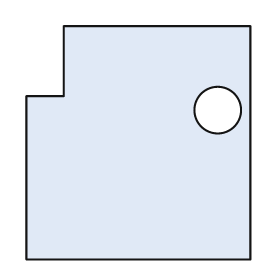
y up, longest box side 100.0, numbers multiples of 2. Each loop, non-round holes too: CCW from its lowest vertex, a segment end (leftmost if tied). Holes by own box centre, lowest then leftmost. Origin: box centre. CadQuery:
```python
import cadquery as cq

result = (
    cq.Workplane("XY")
    .moveTo(-48.0, -50.0)
    .lineTo(48.0, -50.0)
    .lineTo(48.0, 50.0)
    .lineTo(-32.0, 50.0)
    .lineTo(-32.0, 20.0)
    .lineTo(-48.0, 20.0)
    .close()
    .moveTo(34.0, 14.0)
    .circle(10.0)
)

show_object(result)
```